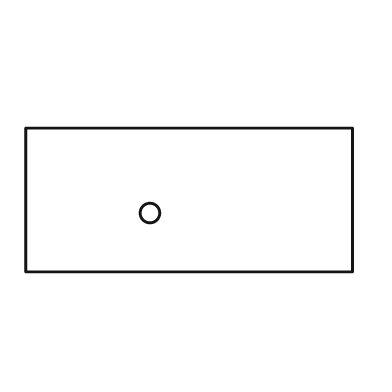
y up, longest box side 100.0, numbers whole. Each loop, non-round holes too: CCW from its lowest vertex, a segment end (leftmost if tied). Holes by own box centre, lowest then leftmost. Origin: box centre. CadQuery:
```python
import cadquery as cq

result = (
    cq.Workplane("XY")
    .moveTo(-50.0, -22.0)
    .lineTo(50.0, -22.0)
    .lineTo(50.0, 22.0)
    .lineTo(-50.0, 22.0)
    .close()
    .moveTo(-12.0, -4.0)
    .circle(3.0)
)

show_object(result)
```